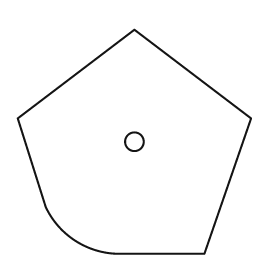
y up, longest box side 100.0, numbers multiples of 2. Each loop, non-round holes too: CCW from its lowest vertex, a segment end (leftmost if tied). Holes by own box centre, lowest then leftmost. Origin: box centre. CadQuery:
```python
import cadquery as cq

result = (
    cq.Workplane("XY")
    .moveTo(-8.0, -48.0)
    .lineTo(30.0, -48.0)
    .lineTo(50.0, 10.0)
    .lineTo(0.0, 48.0)
    .lineTo(-50.0, 10.0)
    .lineTo(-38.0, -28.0)
    .threePointArc((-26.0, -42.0), (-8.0, -48.0))
    .close()
    .moveTo(0.0, 0.0)
    .circle(4.0)
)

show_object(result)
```